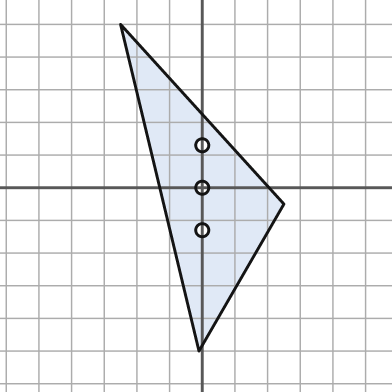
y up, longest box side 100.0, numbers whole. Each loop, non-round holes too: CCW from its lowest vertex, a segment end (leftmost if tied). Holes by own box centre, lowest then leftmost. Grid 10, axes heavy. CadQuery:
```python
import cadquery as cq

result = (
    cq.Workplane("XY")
    .moveTo(-1.0, -50.0)
    .lineTo(25.0, -5.0)
    .lineTo(-25.0, 50.0)
    .close()
    .moveTo(0.0, -13.0)
    .circle(2.0)
    .moveTo(0.0, 0.0)
    .circle(2.0)
    .moveTo(0.0, 13.0)
    .circle(2.0)
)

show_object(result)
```